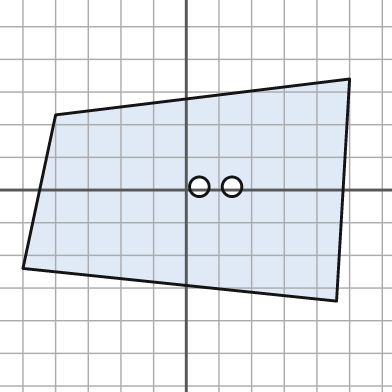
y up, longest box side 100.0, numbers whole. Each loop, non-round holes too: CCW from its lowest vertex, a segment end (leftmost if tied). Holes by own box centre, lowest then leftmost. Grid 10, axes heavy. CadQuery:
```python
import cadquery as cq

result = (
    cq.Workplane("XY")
    .moveTo(46.0, -34.0)
    .lineTo(50.0, 34.0)
    .lineTo(-40.0, 23.0)
    .lineTo(-50.0, -24.0)
    .close()
    .moveTo(4.0, 1.0)
    .circle(3.0)
    .moveTo(14.0, 1.0)
    .circle(3.0)
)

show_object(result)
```